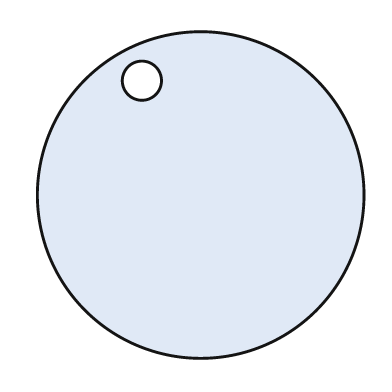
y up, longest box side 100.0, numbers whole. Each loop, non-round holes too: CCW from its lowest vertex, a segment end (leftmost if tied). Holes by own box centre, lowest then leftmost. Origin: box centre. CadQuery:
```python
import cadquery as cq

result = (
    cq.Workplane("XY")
    .moveTo(0.0, 0.0)
    .circle(50.0)
    .moveTo(-18.0, 35.0)
    .circle(6.0)
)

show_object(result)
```